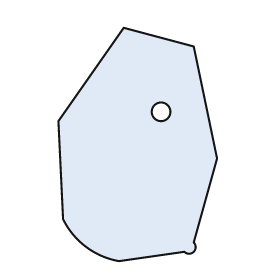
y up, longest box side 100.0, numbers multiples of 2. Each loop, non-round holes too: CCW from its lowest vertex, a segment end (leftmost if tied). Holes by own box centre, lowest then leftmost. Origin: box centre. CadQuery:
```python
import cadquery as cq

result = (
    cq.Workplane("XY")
    .moveTo(-8.0, -50.0)
    .lineTo(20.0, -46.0)
    .threePointArc((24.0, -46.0), (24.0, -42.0))
    .lineTo(34.0, -6.0)
    .lineTo(24.0, 42.0)
    .lineTo(-6.0, 50.0)
    .lineTo(-34.0, 10.0)
    .lineTo(-32.0, -32.0)
    .threePointArc((-22.0, -44.0), (-8.0, -50.0))
    .close()
    .moveTo(10.0, 14.0)
    .circle(4.0)
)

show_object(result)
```